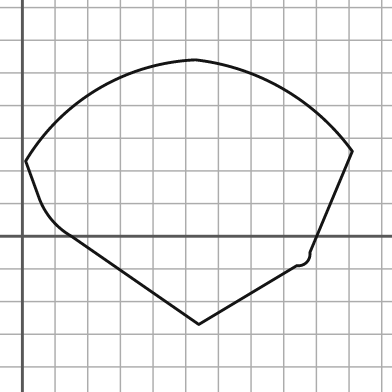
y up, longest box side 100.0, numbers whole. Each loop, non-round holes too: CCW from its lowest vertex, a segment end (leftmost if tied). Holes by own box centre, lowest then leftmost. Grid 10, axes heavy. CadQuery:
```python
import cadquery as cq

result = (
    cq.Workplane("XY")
    .moveTo(54.0, -27.0)
    .lineTo(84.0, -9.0)
    .threePointArc((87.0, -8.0), (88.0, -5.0))
    .lineTo(101.0, 26.0)
    .threePointArc((80.0, 45.0), (53.0, 54.0))
    .threePointArc((23.0, 45.0), (1.0, 23.0))
    .lineTo(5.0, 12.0)
    .threePointArc((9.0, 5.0), (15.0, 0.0))
    .close()
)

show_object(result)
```